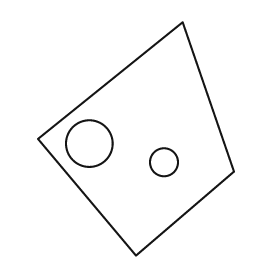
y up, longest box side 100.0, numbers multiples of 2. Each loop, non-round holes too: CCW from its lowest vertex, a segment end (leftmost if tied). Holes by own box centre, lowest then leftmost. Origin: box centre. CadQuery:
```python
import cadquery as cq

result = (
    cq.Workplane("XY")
    .moveTo(0.0, -50.0)
    .lineTo(42.0, -14.0)
    .lineTo(20.0, 50.0)
    .lineTo(-42.0, 0.0)
    .close()
    .moveTo(12.0, -10.0)
    .circle(6.0)
    .moveTo(-20.0, -2.0)
    .circle(10.0)
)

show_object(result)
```